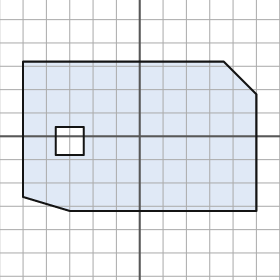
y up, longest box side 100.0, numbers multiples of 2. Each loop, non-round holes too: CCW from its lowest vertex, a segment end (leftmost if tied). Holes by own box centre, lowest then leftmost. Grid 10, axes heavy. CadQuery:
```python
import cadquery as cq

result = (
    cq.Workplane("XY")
    .moveTo(-30.0, -32.0)
    .lineTo(50.0, -32.0)
    .lineTo(50.0, 18.0)
    .lineTo(36.0, 32.0)
    .lineTo(-50.0, 32.0)
    .lineTo(-50.0, -26.0)
    .close()
    .moveTo(-36.0, -8.0)
    .lineTo(-24.0, -8.0)
    .lineTo(-24.0, 4.0)
    .lineTo(-36.0, 4.0)
    .close()
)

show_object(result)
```